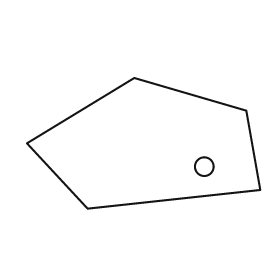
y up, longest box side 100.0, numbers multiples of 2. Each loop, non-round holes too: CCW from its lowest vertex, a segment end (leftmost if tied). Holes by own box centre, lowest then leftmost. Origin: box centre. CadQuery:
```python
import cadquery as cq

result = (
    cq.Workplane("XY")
    .moveTo(-24.0, -28.0)
    .lineTo(50.0, -20.0)
    .lineTo(44.0, 14.0)
    .lineTo(-4.0, 28.0)
    .lineTo(-50.0, 0.0)
    .close()
    .moveTo(26.0, -10.0)
    .circle(4.0)
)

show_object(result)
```